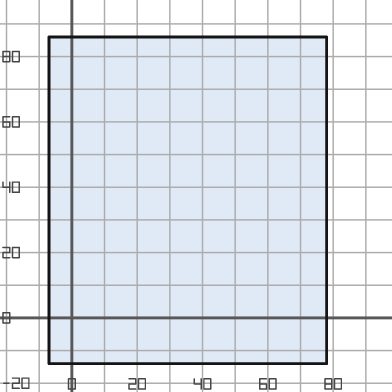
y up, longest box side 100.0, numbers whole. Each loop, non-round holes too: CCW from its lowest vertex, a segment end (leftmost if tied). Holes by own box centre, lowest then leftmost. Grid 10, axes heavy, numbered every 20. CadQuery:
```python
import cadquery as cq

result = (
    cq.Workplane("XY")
    .moveTo(-7.0, -14.0)
    .lineTo(78.0, -14.0)
    .lineTo(78.0, 86.0)
    .lineTo(-7.0, 86.0)
    .close()
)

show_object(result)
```